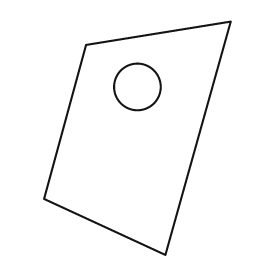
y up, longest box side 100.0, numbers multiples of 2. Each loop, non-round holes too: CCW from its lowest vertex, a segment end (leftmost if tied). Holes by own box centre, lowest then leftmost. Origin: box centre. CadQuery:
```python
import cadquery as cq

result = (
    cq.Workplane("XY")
    .moveTo(12.0, -50.0)
    .lineTo(40.0, 50.0)
    .lineTo(-22.0, 40.0)
    .lineTo(-40.0, -26.0)
    .close()
    .moveTo(0.0, 22.0)
    .circle(10.0)
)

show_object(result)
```